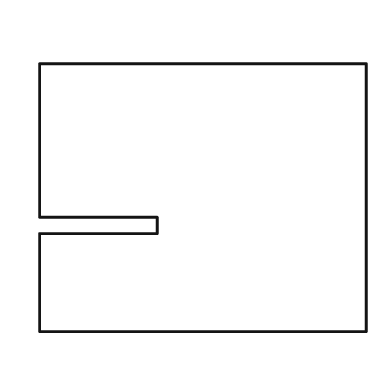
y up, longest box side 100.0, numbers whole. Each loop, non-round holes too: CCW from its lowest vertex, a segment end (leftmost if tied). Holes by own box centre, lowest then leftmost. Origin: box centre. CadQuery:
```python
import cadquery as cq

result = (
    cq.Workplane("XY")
    .moveTo(-50.0, -41.0)
    .lineTo(50.0, -41.0)
    .lineTo(50.0, 41.0)
    .lineTo(-50.0, 41.0)
    .lineTo(-50.0, -6.0)
    .lineTo(-14.0, -6.0)
    .lineTo(-14.0, -11.0)
    .lineTo(-50.0, -11.0)
    .close()
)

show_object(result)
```